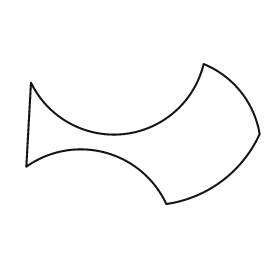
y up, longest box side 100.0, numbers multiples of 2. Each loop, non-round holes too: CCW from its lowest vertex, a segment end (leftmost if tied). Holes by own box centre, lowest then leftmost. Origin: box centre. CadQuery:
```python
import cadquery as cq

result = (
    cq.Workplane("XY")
    .moveTo(10.0, -30.0)
    .threePointArc((34.0, -20.0), (50.0, 0.0))
    .threePointArc((42.0, 18.0), (26.0, 30.0))
    .threePointArc((-8.0, 0.0), (-48.0, 22.0))
    .lineTo(-50.0, -14.0)
    .threePointArc((-16.0, -8.0), (10.0, -30.0))
    .close()
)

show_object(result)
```